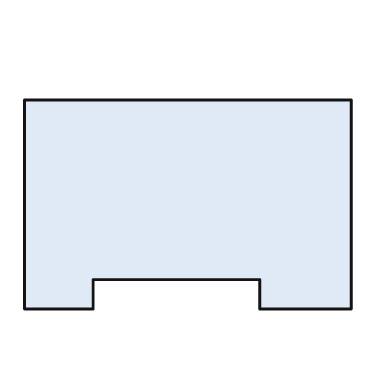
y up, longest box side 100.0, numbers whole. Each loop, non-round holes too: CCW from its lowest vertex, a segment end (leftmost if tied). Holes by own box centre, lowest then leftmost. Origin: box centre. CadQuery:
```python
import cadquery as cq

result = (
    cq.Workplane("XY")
    .moveTo(-50.0, -32.0)
    .lineTo(-29.0, -32.0)
    .lineTo(-29.0, -23.0)
    .lineTo(22.0, -23.0)
    .lineTo(22.0, -32.0)
    .lineTo(50.0, -32.0)
    .lineTo(50.0, 32.0)
    .lineTo(-50.0, 32.0)
    .close()
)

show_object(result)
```